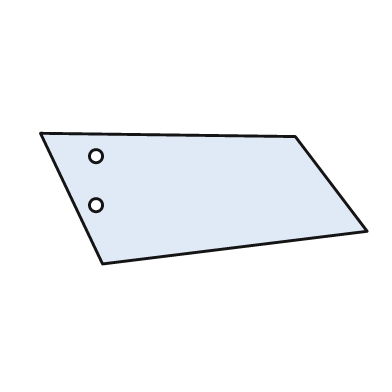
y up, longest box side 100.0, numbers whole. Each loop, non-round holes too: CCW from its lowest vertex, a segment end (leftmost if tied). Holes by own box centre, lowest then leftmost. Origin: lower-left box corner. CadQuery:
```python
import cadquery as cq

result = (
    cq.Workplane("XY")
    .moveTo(19.0, 0.0)
    .lineTo(100.0, 10.0)
    .lineTo(78.0, 39.0)
    .lineTo(0.0, 40.0)
    .close()
    .moveTo(17.0, 18.0)
    .circle(2.0)
    .moveTo(17.0, 33.0)
    .circle(2.0)
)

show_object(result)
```